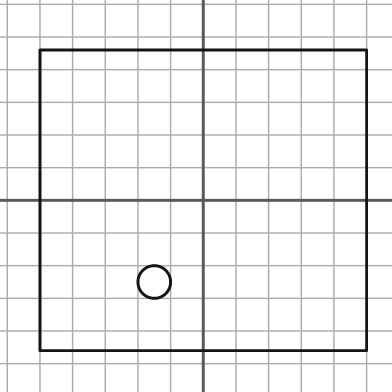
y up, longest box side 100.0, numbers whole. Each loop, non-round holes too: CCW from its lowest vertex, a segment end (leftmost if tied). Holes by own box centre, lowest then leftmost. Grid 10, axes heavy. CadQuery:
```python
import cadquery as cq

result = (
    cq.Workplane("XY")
    .moveTo(-50.0, -46.0)
    .lineTo(50.0, -46.0)
    .lineTo(50.0, 46.0)
    .lineTo(-50.0, 46.0)
    .close()
    .moveTo(-15.0, -25.0)
    .circle(5.0)
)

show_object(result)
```